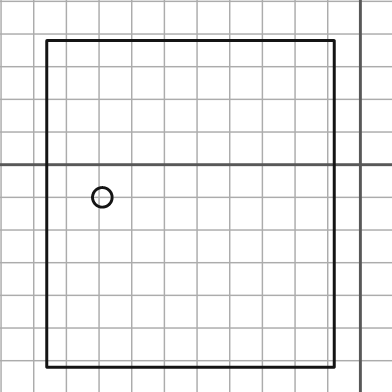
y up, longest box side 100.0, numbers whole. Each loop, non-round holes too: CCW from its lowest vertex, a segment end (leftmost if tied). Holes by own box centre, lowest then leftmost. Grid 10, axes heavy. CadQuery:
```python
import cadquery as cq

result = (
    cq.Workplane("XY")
    .moveTo(-96.0, -62.0)
    .lineTo(-8.0, -62.0)
    .lineTo(-8.0, 38.0)
    .lineTo(-96.0, 38.0)
    .close()
    .moveTo(-79.0, -10.0)
    .circle(3.0)
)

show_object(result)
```